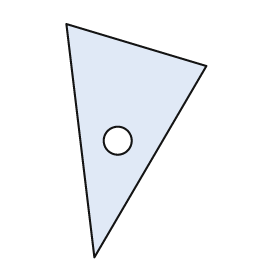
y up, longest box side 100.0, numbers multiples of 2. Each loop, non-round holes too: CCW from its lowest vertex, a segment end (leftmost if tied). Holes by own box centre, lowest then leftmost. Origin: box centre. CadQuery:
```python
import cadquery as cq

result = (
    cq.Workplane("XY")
    .moveTo(-18.0, -50.0)
    .lineTo(30.0, 32.0)
    .lineTo(-30.0, 50.0)
    .close()
    .moveTo(-8.0, 0.0)
    .circle(6.0)
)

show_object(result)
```